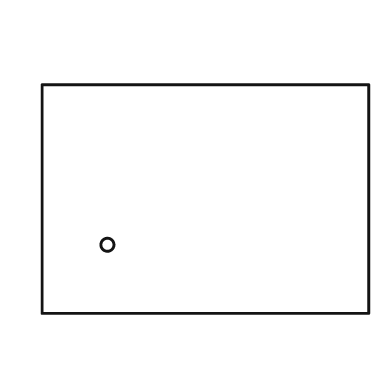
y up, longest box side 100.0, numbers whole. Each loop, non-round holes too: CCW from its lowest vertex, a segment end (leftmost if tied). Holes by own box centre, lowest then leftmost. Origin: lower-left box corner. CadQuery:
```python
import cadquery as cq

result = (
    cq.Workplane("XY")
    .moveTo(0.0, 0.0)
    .lineTo(100.0, 0.0)
    .lineTo(100.0, 70.0)
    .lineTo(0.0, 70.0)
    .close()
    .moveTo(20.0, 21.0)
    .circle(2.0)
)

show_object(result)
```